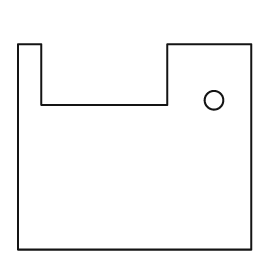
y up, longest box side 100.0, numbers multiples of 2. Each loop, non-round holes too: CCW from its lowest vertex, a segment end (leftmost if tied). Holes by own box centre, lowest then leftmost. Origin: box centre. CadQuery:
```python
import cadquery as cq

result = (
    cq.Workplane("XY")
    .moveTo(-50.0, -44.0)
    .lineTo(50.0, -44.0)
    .lineTo(50.0, 44.0)
    .lineTo(14.0, 44.0)
    .lineTo(14.0, 18.0)
    .lineTo(-40.0, 18.0)
    .lineTo(-40.0, 44.0)
    .lineTo(-50.0, 44.0)
    .close()
    .moveTo(34.0, 20.0)
    .circle(4.0)
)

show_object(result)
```